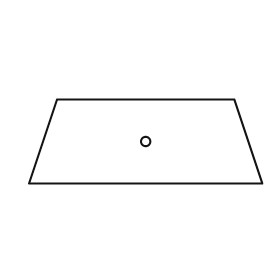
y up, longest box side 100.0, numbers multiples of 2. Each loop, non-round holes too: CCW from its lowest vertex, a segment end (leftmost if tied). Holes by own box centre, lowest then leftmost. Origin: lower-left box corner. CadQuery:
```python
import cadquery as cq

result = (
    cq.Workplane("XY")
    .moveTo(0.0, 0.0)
    .lineTo(100.0, 0.0)
    .lineTo(88.0, 36.0)
    .lineTo(12.0, 36.0)
    .close()
    .moveTo(50.0, 18.0)
    .circle(2.0)
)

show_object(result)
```